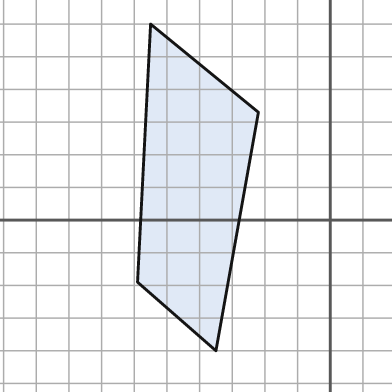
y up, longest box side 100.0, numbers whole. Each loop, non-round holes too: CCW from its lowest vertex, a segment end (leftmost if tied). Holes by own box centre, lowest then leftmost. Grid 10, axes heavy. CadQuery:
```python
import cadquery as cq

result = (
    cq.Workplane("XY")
    .moveTo(-35.0, -40.0)
    .lineTo(-22.0, 33.0)
    .lineTo(-55.0, 60.0)
    .lineTo(-59.0, -19.0)
    .close()
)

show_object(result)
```